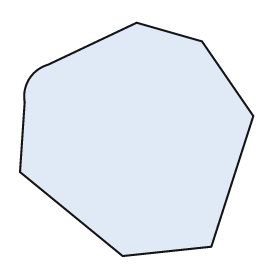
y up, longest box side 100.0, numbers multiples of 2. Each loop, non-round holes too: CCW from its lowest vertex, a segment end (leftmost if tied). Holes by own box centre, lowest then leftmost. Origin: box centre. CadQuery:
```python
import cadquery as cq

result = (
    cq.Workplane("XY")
    .moveTo(-6.0, -50.0)
    .lineTo(32.0, -46.0)
    .lineTo(50.0, 10.0)
    .lineTo(28.0, 42.0)
    .lineTo(0.0, 50.0)
    .lineTo(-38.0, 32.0)
    .threePointArc((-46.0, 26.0), (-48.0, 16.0))
    .lineTo(-50.0, -14.0)
    .close()
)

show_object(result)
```